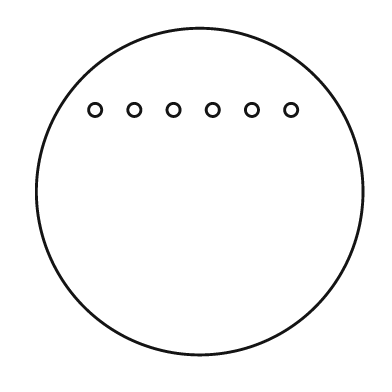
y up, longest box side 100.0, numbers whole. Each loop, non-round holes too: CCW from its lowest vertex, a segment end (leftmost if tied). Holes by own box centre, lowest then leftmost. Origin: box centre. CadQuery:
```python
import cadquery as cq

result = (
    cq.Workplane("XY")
    .moveTo(0.0, 0.0)
    .circle(50.0)
    .moveTo(-32.0, 25.0)
    .circle(2.0)
    .moveTo(-20.0, 25.0)
    .circle(2.0)
    .moveTo(-8.0, 25.0)
    .circle(2.0)
    .moveTo(4.0, 25.0)
    .circle(2.0)
    .moveTo(16.0, 25.0)
    .circle(2.0)
    .moveTo(28.0, 25.0)
    .circle(2.0)
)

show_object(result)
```